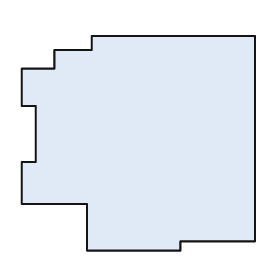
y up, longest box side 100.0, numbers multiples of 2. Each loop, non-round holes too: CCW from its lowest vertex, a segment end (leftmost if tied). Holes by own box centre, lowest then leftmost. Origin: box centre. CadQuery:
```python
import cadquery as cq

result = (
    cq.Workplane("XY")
    .moveTo(-22.0, -46.0)
    .lineTo(18.0, -46.0)
    .lineTo(18.0, -42.0)
    .lineTo(50.0, -42.0)
    .lineTo(50.0, 46.0)
    .lineTo(-20.0, 46.0)
    .lineTo(-20.0, 40.0)
    .lineTo(-36.0, 40.0)
    .lineTo(-36.0, 32.0)
    .lineTo(-50.0, 32.0)
    .lineTo(-50.0, 16.0)
    .lineTo(-44.0, 16.0)
    .lineTo(-44.0, -8.0)
    .lineTo(-50.0, -8.0)
    .lineTo(-50.0, -26.0)
    .lineTo(-22.0, -26.0)
    .close()
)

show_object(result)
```